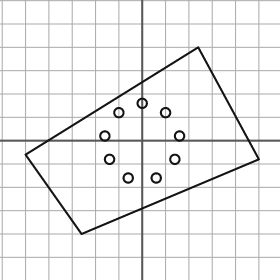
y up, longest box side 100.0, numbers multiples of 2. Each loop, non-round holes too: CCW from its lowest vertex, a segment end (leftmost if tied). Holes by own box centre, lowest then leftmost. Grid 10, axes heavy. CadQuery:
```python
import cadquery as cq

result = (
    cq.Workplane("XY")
    .moveTo(-26.0, -40.0)
    .lineTo(50.0, -8.0)
    .lineTo(24.0, 40.0)
    .lineTo(-50.0, -6.0)
    .close()
    .moveTo(-6.0, -16.0)
    .circle(2.0)
    .moveTo(6.0, -16.0)
    .circle(2.0)
    .moveTo(-14.0, -8.0)
    .circle(2.0)
    .moveTo(14.0, -8.0)
    .circle(2.0)
    .moveTo(-16.0, 2.0)
    .circle(2.0)
    .moveTo(16.0, 2.0)
    .circle(2.0)
    .moveTo(-10.0, 12.0)
    .circle(2.0)
    .moveTo(10.0, 12.0)
    .circle(2.0)
    .moveTo(0.0, 16.0)
    .circle(2.0)
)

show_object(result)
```